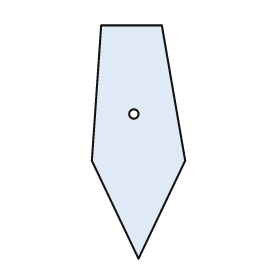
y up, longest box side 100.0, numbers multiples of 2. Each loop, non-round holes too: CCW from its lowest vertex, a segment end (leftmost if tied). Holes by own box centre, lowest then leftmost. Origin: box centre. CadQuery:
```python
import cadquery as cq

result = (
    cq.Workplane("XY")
    .moveTo(0.0, -50.0)
    .lineTo(20.0, -8.0)
    .lineTo(10.0, 50.0)
    .lineTo(-16.0, 50.0)
    .lineTo(-20.0, -8.0)
    .close()
    .moveTo(-2.0, 12.0)
    .circle(2.0)
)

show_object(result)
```